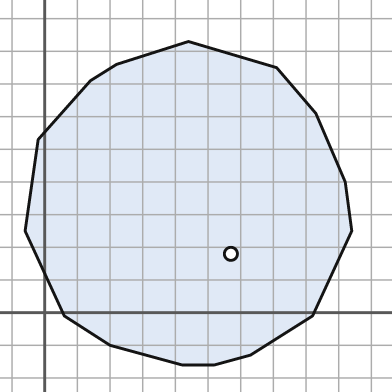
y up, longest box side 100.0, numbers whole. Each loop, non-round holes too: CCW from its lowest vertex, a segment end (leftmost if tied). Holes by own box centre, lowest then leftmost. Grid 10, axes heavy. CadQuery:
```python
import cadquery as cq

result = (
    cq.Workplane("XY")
    .moveTo(42.0, -16.0)
    .lineTo(52.0, -16.0)
    .lineTo(63.0, -13.0)
    .lineTo(82.0, -1.0)
    .lineTo(94.0, 25.0)
    .lineTo(92.0, 40.0)
    .lineTo(83.0, 61.0)
    .lineTo(71.0, 75.0)
    .lineTo(44.0, 83.0)
    .lineTo(22.0, 76.0)
    .lineTo(14.0, 71.0)
    .lineTo(-2.0, 53.0)
    .lineTo(-6.0, 25.0)
    .lineTo(6.0, -1.0)
    .lineTo(20.0, -10.0)
    .close()
    .moveTo(57.0, 18.0)
    .circle(2.0)
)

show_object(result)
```